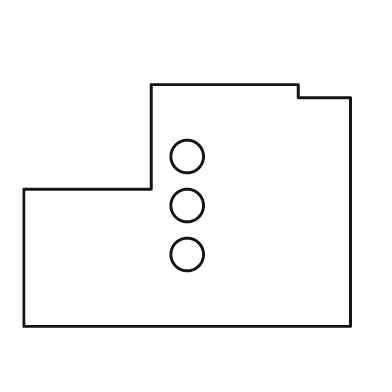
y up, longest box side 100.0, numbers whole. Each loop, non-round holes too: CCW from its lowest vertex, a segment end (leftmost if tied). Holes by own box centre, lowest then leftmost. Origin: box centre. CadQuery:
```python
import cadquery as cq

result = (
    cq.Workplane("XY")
    .moveTo(-50.0, -37.0)
    .lineTo(50.0, -37.0)
    .lineTo(50.0, 33.0)
    .lineTo(34.0, 33.0)
    .lineTo(34.0, 37.0)
    .lineTo(-11.0, 37.0)
    .lineTo(-11.0, 5.0)
    .lineTo(-50.0, 5.0)
    .close()
    .moveTo(0.0, -15.0)
    .circle(5.0)
    .moveTo(0.0, 0.0)
    .circle(5.0)
    .moveTo(0.0, 15.0)
    .circle(5.0)
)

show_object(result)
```